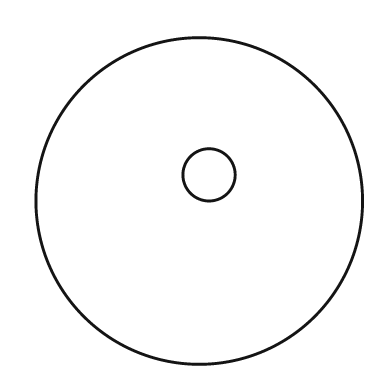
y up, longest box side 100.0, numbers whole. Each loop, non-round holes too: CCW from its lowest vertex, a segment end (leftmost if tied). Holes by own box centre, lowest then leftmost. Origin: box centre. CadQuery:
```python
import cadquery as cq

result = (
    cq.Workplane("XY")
    .moveTo(0.0, 0.0)
    .circle(50.0)
    .moveTo(3.0, 8.0)
    .circle(8.0)
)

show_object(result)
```